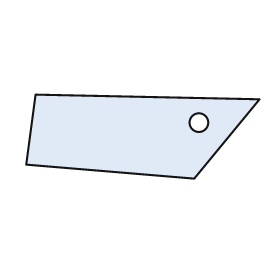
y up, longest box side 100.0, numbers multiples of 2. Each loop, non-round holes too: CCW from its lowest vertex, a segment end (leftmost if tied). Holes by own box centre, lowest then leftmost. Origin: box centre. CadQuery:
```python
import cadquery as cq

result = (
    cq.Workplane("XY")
    .moveTo(22.0, -18.0)
    .lineTo(50.0, 16.0)
    .lineTo(-46.0, 18.0)
    .lineTo(-50.0, -12.0)
    .close()
    .moveTo(24.0, 6.0)
    .circle(4.0)
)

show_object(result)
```